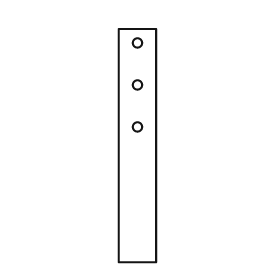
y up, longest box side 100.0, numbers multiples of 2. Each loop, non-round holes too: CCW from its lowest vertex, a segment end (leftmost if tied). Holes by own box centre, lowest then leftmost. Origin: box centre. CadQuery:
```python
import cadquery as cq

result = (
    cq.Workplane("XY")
    .moveTo(-8.0, -50.0)
    .lineTo(8.0, -50.0)
    .lineTo(8.0, 50.0)
    .lineTo(-8.0, 50.0)
    .close()
    .moveTo(0.0, 8.0)
    .circle(2.0)
    .moveTo(0.0, 26.0)
    .circle(2.0)
    .moveTo(0.0, 44.0)
    .circle(2.0)
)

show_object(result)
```